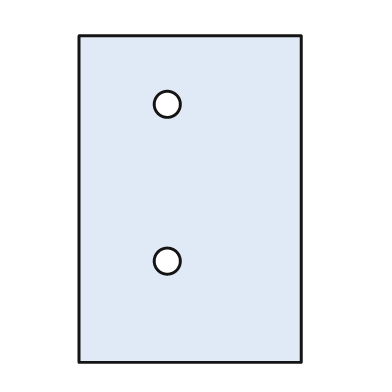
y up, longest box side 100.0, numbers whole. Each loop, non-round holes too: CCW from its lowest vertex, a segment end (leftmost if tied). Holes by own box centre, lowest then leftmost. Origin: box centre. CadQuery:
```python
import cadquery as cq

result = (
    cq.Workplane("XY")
    .moveTo(-34.0, -50.0)
    .lineTo(34.0, -50.0)
    .lineTo(34.0, 50.0)
    .lineTo(-34.0, 50.0)
    .close()
    .moveTo(-7.0, -19.0)
    .circle(4.0)
    .moveTo(-7.0, 29.0)
    .circle(4.0)
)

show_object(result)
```